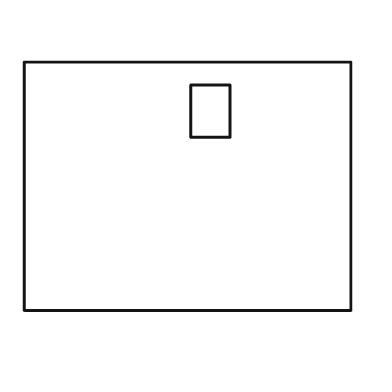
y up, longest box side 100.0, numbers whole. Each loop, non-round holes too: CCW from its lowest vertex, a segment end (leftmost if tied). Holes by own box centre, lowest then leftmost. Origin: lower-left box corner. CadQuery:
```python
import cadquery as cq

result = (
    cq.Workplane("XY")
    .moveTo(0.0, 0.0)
    .lineTo(100.0, 0.0)
    .lineTo(100.0, 76.0)
    .lineTo(0.0, 76.0)
    .close()
    .moveTo(51.0, 53.0)
    .lineTo(63.0, 53.0)
    .lineTo(63.0, 69.0)
    .lineTo(51.0, 69.0)
    .close()
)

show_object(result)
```